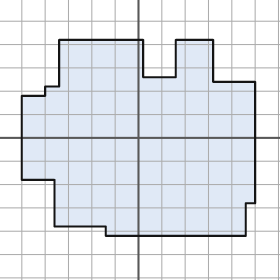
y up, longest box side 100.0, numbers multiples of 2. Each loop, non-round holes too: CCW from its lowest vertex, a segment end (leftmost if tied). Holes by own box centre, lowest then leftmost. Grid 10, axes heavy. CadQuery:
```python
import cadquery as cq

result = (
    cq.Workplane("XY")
    .moveTo(-14.0, -42.0)
    .lineTo(46.0, -42.0)
    .lineTo(46.0, -28.0)
    .lineTo(50.0, -28.0)
    .lineTo(50.0, 24.0)
    .lineTo(32.0, 24.0)
    .lineTo(32.0, 42.0)
    .lineTo(16.0, 42.0)
    .lineTo(16.0, 26.0)
    .lineTo(2.0, 26.0)
    .lineTo(2.0, 42.0)
    .lineTo(-34.0, 42.0)
    .lineTo(-34.0, 22.0)
    .lineTo(-40.0, 22.0)
    .lineTo(-40.0, 18.0)
    .lineTo(-50.0, 18.0)
    .lineTo(-50.0, -18.0)
    .lineTo(-36.0, -18.0)
    .lineTo(-36.0, -38.0)
    .lineTo(-14.0, -38.0)
    .close()
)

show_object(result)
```